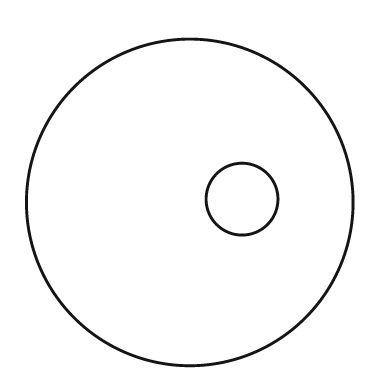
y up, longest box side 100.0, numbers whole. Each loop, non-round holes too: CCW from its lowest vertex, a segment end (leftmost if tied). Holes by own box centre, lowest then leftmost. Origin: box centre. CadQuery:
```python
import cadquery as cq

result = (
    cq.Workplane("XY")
    .moveTo(0.0, 0.0)
    .circle(50.0)
    .moveTo(16.0, 1.0)
    .circle(11.0)
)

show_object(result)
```